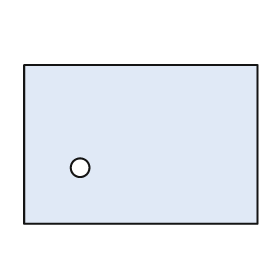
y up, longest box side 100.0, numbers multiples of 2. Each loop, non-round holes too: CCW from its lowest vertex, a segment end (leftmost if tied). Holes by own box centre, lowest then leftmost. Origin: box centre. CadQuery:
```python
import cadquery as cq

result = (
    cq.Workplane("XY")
    .moveTo(-50.0, -34.0)
    .lineTo(50.0, -34.0)
    .lineTo(50.0, 34.0)
    .lineTo(-50.0, 34.0)
    .close()
    .moveTo(-26.0, -10.0)
    .circle(4.0)
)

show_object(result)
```